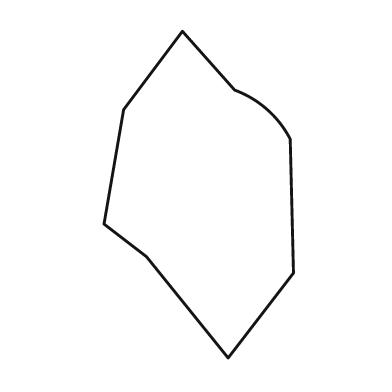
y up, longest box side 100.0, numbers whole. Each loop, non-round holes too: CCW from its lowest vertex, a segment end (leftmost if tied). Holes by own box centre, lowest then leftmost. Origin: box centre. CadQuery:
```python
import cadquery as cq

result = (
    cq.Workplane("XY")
    .moveTo(9.0, -50.0)
    .lineTo(29.0, -24.0)
    .lineTo(28.0, 17.0)
    .threePointArc((21.0, 26.0), (11.0, 32.0))
    .lineTo(-5.0, 50.0)
    .lineTo(-23.0, 26.0)
    .lineTo(-29.0, -9.0)
    .lineTo(-16.0, -19.0)
    .close()
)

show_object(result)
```